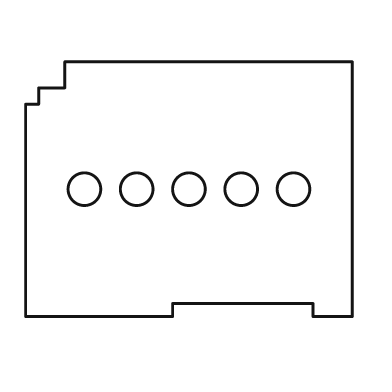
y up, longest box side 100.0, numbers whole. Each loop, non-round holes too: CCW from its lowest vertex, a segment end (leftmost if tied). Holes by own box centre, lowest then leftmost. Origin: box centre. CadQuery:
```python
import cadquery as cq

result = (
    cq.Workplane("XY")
    .moveTo(-50.0, -39.0)
    .lineTo(-5.0, -39.0)
    .lineTo(-5.0, -35.0)
    .lineTo(38.0, -35.0)
    .lineTo(38.0, -39.0)
    .lineTo(50.0, -39.0)
    .lineTo(50.0, 39.0)
    .lineTo(-38.0, 39.0)
    .lineTo(-38.0, 31.0)
    .lineTo(-46.0, 31.0)
    .lineTo(-46.0, 26.0)
    .lineTo(-50.0, 26.0)
    .close()
    .moveTo(-32.0, 0.0)
    .circle(5.0)
    .moveTo(-16.0, 0.0)
    .circle(5.0)
    .moveTo(0.0, 0.0)
    .circle(5.0)
    .moveTo(16.0, 0.0)
    .circle(5.0)
    .moveTo(32.0, 0.0)
    .circle(5.0)
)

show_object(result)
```